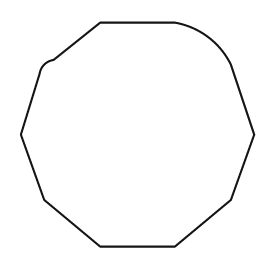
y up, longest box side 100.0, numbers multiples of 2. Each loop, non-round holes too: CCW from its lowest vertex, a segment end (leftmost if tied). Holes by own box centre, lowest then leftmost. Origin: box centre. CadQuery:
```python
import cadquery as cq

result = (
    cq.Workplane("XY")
    .moveTo(-16.0, -48.0)
    .lineTo(16.0, -48.0)
    .lineTo(40.0, -28.0)
    .lineTo(50.0, 0.0)
    .lineTo(40.0, 30.0)
    .threePointArc((30.0, 42.0), (16.0, 48.0))
    .lineTo(-16.0, 48.0)
    .lineTo(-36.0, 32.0)
    .threePointArc((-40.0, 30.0), (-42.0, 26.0))
    .lineTo(-50.0, 0.0)
    .lineTo(-40.0, -28.0)
    .close()
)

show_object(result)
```